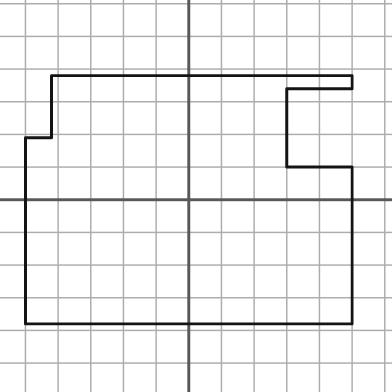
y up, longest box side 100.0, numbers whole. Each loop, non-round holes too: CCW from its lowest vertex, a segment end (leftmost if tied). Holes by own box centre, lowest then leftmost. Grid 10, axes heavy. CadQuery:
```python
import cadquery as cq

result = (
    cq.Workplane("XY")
    .moveTo(-50.0, -38.0)
    .lineTo(50.0, -38.0)
    .lineTo(50.0, 10.0)
    .lineTo(30.0, 10.0)
    .lineTo(30.0, 34.0)
    .lineTo(50.0, 34.0)
    .lineTo(50.0, 38.0)
    .lineTo(-42.0, 38.0)
    .lineTo(-42.0, 19.0)
    .lineTo(-50.0, 19.0)
    .close()
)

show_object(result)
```